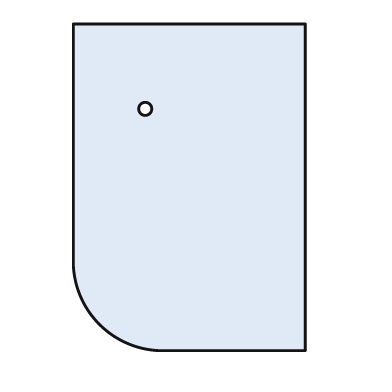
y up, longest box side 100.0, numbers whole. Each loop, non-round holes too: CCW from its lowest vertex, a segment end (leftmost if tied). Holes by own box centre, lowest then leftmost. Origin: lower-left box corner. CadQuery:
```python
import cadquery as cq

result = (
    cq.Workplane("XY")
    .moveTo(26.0, 0.0)
    .lineTo(71.0, 0.0)
    .lineTo(71.0, 100.0)
    .lineTo(0.0, 100.0)
    .lineTo(0.0, 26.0)
    .threePointArc((8.0, 8.0), (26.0, 0.0))
    .close()
    .moveTo(22.0, 74.0)
    .circle(2.0)
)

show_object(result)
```